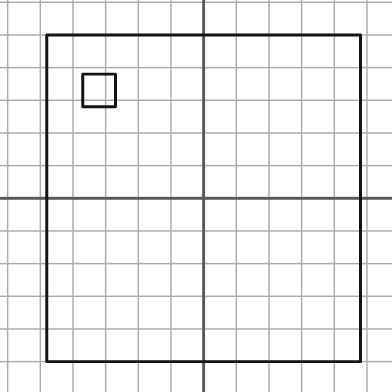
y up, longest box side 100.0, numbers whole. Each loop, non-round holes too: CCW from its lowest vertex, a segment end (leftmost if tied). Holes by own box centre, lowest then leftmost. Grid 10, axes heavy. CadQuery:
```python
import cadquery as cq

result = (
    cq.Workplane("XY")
    .moveTo(-48.0, -50.0)
    .lineTo(48.0, -50.0)
    .lineTo(48.0, 50.0)
    .lineTo(-48.0, 50.0)
    .close()
    .moveTo(-37.0, 28.0)
    .lineTo(-27.0, 28.0)
    .lineTo(-27.0, 38.0)
    .lineTo(-37.0, 38.0)
    .close()
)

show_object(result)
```